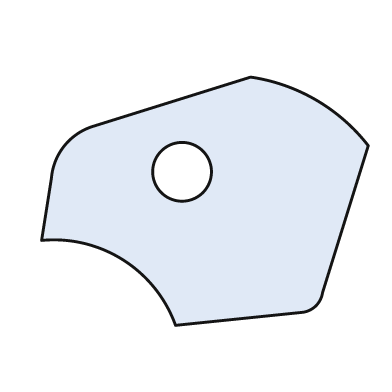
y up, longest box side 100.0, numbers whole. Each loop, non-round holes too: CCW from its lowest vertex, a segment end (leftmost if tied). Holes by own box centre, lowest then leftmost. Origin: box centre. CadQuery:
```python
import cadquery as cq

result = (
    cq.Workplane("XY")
    .moveTo(-9.0, -38.0)
    .lineTo(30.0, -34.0)
    .threePointArc((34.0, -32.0), (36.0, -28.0))
    .lineTo(50.0, 17.0)
    .threePointArc((34.0, 31.0), (14.0, 38.0))
    .lineTo(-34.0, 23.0)
    .threePointArc((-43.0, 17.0), (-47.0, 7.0))
    .lineTo(-50.0, -12.0)
    .threePointArc((-25.0, -18.0), (-9.0, -38.0))
    .close()
    .moveTo(-7.0, 9.0)
    .circle(9.0)
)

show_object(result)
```